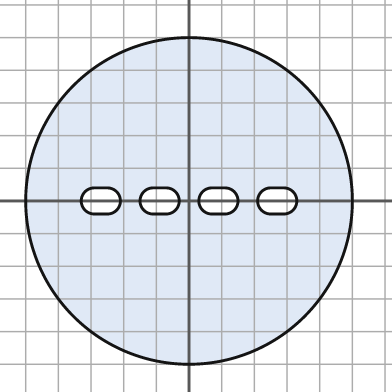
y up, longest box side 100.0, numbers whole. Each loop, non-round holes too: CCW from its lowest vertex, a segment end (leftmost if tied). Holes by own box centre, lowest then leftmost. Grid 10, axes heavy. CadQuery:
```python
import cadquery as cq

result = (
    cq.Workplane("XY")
    .moveTo(0.0, 0.0)
    .circle(50.0)
    .moveTo(-29.0, -4.0)
    .lineTo(-25.0, -4.0)
    .threePointArc((-21.0, 0.0), (-25.0, 4.0))
    .lineTo(-29.0, 4.0)
    .threePointArc((-33.0, 0.0), (-29.0, -4.0))
    .close()
    .moveTo(-11.0, -4.0)
    .lineTo(-7.0, -4.0)
    .threePointArc((-3.0, 0.0), (-7.0, 4.0))
    .lineTo(-11.0, 4.0)
    .threePointArc((-15.0, 0.0), (-11.0, -4.0))
    .close()
    .moveTo(7.0, -4.0)
    .lineTo(11.0, -4.0)
    .threePointArc((15.0, 0.0), (11.0, 4.0))
    .lineTo(7.0, 4.0)
    .threePointArc((3.0, 0.0), (7.0, -4.0))
    .close()
    .moveTo(25.0, -4.0)
    .lineTo(29.0, -4.0)
    .threePointArc((33.0, 0.0), (29.0, 4.0))
    .lineTo(25.0, 4.0)
    .threePointArc((21.0, 0.0), (25.0, -4.0))
    .close()
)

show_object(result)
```